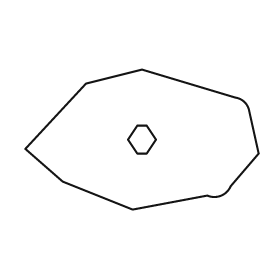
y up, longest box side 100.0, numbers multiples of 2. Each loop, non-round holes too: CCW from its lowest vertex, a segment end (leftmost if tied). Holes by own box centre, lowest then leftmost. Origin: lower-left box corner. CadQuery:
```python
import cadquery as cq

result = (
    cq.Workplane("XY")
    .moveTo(46.0, 0.0)
    .lineTo(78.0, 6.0)
    .threePointArc((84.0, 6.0), (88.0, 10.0))
    .lineTo(100.0, 24.0)
    .lineTo(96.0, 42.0)
    .threePointArc((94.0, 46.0), (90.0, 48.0))
    .lineTo(50.0, 60.0)
    .lineTo(26.0, 54.0)
    .lineTo(0.0, 26.0)
    .lineTo(16.0, 12.0)
    .close()
    .moveTo(48.0, 24.0)
    .lineTo(52.0, 24.0)
    .lineTo(56.0, 30.0)
    .lineTo(52.0, 36.0)
    .lineTo(48.0, 36.0)
    .lineTo(44.0, 30.0)
    .close()
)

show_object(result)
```